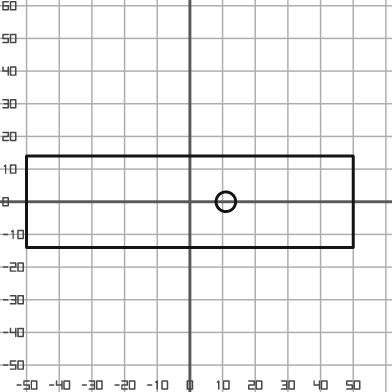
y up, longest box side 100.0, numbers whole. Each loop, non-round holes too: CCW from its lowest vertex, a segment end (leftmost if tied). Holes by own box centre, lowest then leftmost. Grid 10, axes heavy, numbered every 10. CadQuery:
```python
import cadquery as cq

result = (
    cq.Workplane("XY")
    .moveTo(-50.0, -14.0)
    .lineTo(50.0, -14.0)
    .lineTo(50.0, 14.0)
    .lineTo(-50.0, 14.0)
    .close()
    .moveTo(11.0, 0.0)
    .circle(3.0)
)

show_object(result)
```